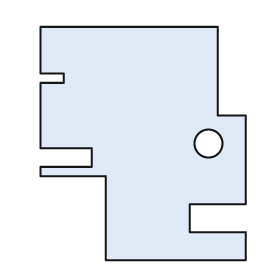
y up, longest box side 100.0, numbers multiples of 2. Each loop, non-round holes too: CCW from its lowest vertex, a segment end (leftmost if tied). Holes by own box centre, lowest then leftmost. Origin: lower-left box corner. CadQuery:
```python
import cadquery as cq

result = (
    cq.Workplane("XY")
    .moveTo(28.0, 0.0)
    .lineTo(88.0, 0.0)
    .lineTo(88.0, 12.0)
    .lineTo(64.0, 12.0)
    .lineTo(64.0, 24.0)
    .lineTo(88.0, 24.0)
    .lineTo(88.0, 62.0)
    .lineTo(76.0, 62.0)
    .lineTo(76.0, 100.0)
    .lineTo(0.0, 100.0)
    .lineTo(0.0, 80.0)
    .lineTo(10.0, 80.0)
    .lineTo(10.0, 76.0)
    .lineTo(0.0, 76.0)
    .lineTo(0.0, 48.0)
    .lineTo(22.0, 48.0)
    .lineTo(22.0, 40.0)
    .lineTo(0.0, 40.0)
    .lineTo(0.0, 36.0)
    .lineTo(28.0, 36.0)
    .close()
    .moveTo(72.0, 50.0)
    .circle(6.0)
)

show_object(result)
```